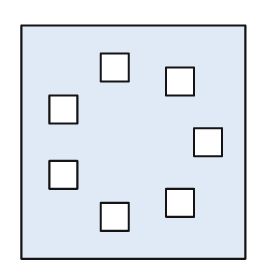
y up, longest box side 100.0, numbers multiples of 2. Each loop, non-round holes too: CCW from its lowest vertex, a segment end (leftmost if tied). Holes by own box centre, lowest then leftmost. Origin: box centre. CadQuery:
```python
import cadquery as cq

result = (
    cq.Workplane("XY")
    .moveTo(-48.0, -50.0)
    .lineTo(48.0, -50.0)
    .lineTo(48.0, 50.0)
    .lineTo(-48.0, 50.0)
    .close()
    .moveTo(-14.0, -38.0)
    .lineTo(-2.0, -38.0)
    .lineTo(-2.0, -26.0)
    .lineTo(-14.0, -26.0)
    .close()
    .moveTo(14.0, -32.0)
    .lineTo(26.0, -32.0)
    .lineTo(26.0, -20.0)
    .lineTo(14.0, -20.0)
    .close()
    .moveTo(-36.0, -20.0)
    .lineTo(-24.0, -20.0)
    .lineTo(-24.0, -8.0)
    .lineTo(-36.0, -8.0)
    .close()
    .moveTo(26.0, -6.0)
    .lineTo(38.0, -6.0)
    .lineTo(38.0, 6.0)
    .lineTo(26.0, 6.0)
    .close()
    .moveTo(-36.0, 8.0)
    .lineTo(-24.0, 8.0)
    .lineTo(-24.0, 20.0)
    .lineTo(-36.0, 20.0)
    .close()
    .moveTo(14.0, 20.0)
    .lineTo(26.0, 20.0)
    .lineTo(26.0, 32.0)
    .lineTo(14.0, 32.0)
    .close()
    .moveTo(-14.0, 26.0)
    .lineTo(-2.0, 26.0)
    .lineTo(-2.0, 38.0)
    .lineTo(-14.0, 38.0)
    .close()
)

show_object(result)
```